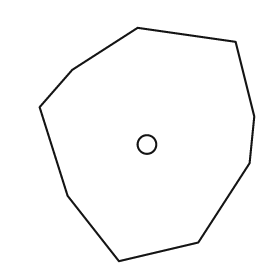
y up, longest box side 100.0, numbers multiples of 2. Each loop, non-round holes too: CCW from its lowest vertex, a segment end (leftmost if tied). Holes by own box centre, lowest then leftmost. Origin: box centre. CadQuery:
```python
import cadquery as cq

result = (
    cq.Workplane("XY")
    .moveTo(-12.0, -50.0)
    .lineTo(22.0, -42.0)
    .lineTo(44.0, -8.0)
    .lineTo(46.0, 12.0)
    .lineTo(38.0, 44.0)
    .lineTo(-4.0, 50.0)
    .lineTo(-32.0, 32.0)
    .lineTo(-46.0, 16.0)
    .lineTo(-34.0, -22.0)
    .close()
    .moveTo(0.0, 0.0)
    .circle(4.0)
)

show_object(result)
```